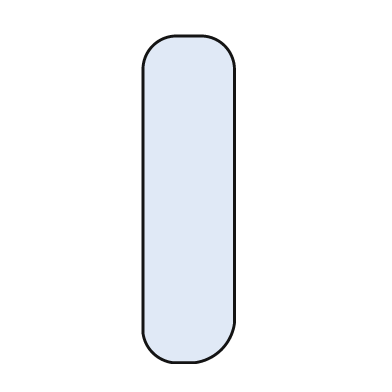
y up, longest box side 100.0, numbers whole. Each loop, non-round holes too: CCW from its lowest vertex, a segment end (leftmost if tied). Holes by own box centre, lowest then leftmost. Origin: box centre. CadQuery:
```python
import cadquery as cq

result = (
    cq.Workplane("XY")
    .moveTo(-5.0, -50.0)
    .lineTo(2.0, -50.0)
    .threePointArc((10.0, -46.0), (14.0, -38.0))
    .lineTo(14.0, 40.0)
    .threePointArc((11.0, 47.0), (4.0, 50.0))
    .lineTo(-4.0, 50.0)
    .threePointArc((-11.0, 47.0), (-14.0, 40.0))
    .lineTo(-14.0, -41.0)
    .threePointArc((-11.0, -47.0), (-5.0, -50.0))
    .close()
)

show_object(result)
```